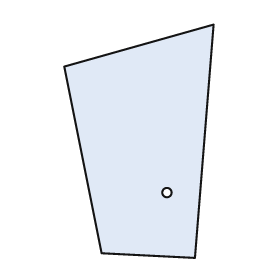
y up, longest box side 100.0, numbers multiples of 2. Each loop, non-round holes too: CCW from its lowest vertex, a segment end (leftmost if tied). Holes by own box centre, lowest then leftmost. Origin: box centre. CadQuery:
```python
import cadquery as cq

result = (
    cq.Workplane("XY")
    .moveTo(24.0, -50.0)
    .lineTo(32.0, 50.0)
    .lineTo(-32.0, 32.0)
    .lineTo(-16.0, -48.0)
    .close()
    .moveTo(12.0, -22.0)
    .circle(2.0)
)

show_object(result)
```